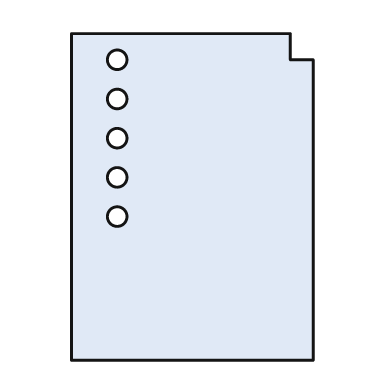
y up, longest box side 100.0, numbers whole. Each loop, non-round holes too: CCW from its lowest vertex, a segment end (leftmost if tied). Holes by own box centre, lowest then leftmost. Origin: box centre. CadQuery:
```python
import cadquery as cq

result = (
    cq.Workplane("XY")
    .moveTo(-37.0, -50.0)
    .lineTo(37.0, -50.0)
    .lineTo(37.0, 42.0)
    .lineTo(30.0, 42.0)
    .lineTo(30.0, 50.0)
    .lineTo(-37.0, 50.0)
    .close()
    .moveTo(-23.0, -6.0)
    .circle(3.0)
    .moveTo(-23.0, 6.0)
    .circle(3.0)
    .moveTo(-23.0, 18.0)
    .circle(3.0)
    .moveTo(-23.0, 30.0)
    .circle(3.0)
    .moveTo(-23.0, 42.0)
    .circle(3.0)
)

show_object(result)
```